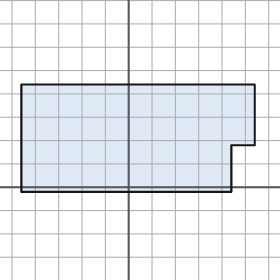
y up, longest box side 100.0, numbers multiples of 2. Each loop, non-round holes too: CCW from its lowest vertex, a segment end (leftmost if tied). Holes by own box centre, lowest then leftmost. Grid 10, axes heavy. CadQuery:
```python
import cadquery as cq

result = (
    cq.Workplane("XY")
    .moveTo(-46.0, -2.0)
    .lineTo(44.0, -2.0)
    .lineTo(44.0, 18.0)
    .lineTo(54.0, 18.0)
    .lineTo(54.0, 44.0)
    .lineTo(-46.0, 44.0)
    .close()
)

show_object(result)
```